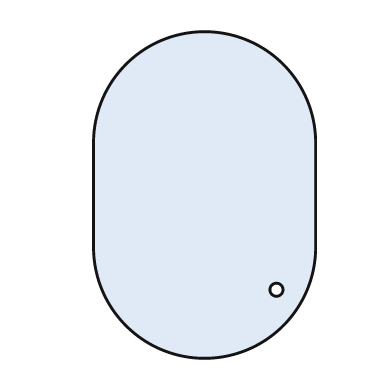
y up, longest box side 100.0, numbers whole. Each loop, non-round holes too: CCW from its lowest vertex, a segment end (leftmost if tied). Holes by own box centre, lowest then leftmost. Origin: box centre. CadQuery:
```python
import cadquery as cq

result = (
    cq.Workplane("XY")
    .moveTo(-34.0, -16.0)
    .threePointArc((0.0, -50.0), (34.0, -16.0))
    .lineTo(34.0, 16.0)
    .threePointArc((0.0, 50.0), (-34.0, 16.0))
    .close()
    .moveTo(22.0, -29.0)
    .circle(2.0)
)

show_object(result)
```